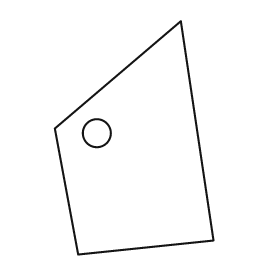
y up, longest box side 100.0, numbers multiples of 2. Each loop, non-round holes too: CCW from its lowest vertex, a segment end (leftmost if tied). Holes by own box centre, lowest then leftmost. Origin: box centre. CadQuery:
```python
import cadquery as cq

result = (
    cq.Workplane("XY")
    .moveTo(-24.0, -50.0)
    .lineTo(34.0, -44.0)
    .lineTo(20.0, 50.0)
    .lineTo(-34.0, 4.0)
    .close()
    .moveTo(-16.0, 2.0)
    .circle(6.0)
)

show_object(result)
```